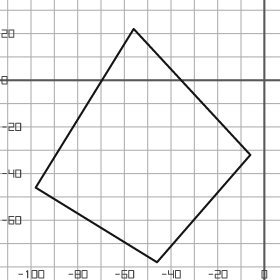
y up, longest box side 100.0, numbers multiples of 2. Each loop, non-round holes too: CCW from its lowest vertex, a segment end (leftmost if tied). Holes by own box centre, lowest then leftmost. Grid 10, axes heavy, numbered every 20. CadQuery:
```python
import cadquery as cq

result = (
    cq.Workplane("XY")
    .moveTo(-46.0, -78.0)
    .lineTo(-6.0, -32.0)
    .lineTo(-56.0, 22.0)
    .lineTo(-98.0, -46.0)
    .close()
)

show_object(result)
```